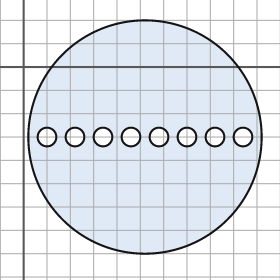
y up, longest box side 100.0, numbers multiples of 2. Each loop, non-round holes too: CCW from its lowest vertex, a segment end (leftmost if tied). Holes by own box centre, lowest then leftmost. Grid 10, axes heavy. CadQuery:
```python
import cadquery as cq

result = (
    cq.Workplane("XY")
    .moveTo(52.0, -30.0)
    .circle(50.0)
    .moveTo(10.0, -30.0)
    .circle(4.0)
    .moveTo(22.0, -30.0)
    .circle(4.0)
    .moveTo(34.0, -30.0)
    .circle(4.0)
    .moveTo(46.0, -30.0)
    .circle(4.0)
    .moveTo(58.0, -30.0)
    .circle(4.0)
    .moveTo(70.0, -30.0)
    .circle(4.0)
    .moveTo(82.0, -30.0)
    .circle(4.0)
    .moveTo(94.0, -30.0)
    .circle(4.0)
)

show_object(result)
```